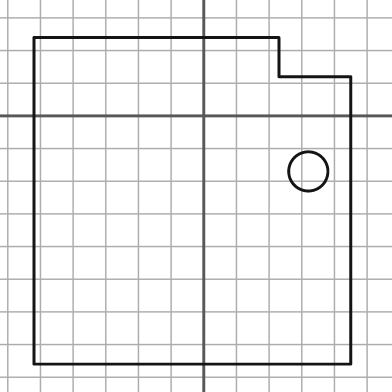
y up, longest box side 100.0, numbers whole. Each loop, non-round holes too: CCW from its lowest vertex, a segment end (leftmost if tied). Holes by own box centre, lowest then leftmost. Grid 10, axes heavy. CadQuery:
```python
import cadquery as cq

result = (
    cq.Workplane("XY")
    .moveTo(-52.0, -76.0)
    .lineTo(45.0, -76.0)
    .lineTo(45.0, 12.0)
    .lineTo(23.0, 12.0)
    .lineTo(23.0, 24.0)
    .lineTo(-52.0, 24.0)
    .close()
    .moveTo(32.0, -17.0)
    .circle(6.0)
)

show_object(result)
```